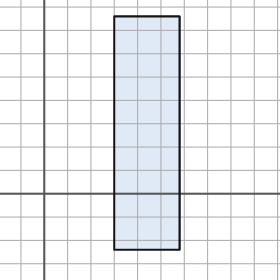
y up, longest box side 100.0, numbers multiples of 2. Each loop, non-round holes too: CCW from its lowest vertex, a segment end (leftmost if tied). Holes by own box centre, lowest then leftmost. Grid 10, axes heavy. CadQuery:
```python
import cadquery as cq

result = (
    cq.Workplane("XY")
    .moveTo(30.0, -24.0)
    .lineTo(58.0, -24.0)
    .lineTo(58.0, 76.0)
    .lineTo(30.0, 76.0)
    .close()
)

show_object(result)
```